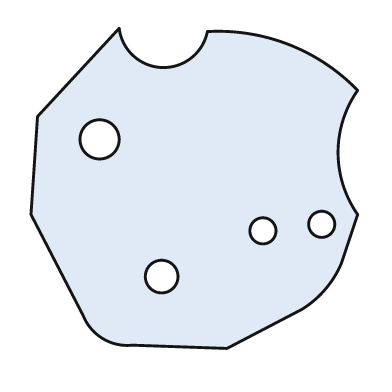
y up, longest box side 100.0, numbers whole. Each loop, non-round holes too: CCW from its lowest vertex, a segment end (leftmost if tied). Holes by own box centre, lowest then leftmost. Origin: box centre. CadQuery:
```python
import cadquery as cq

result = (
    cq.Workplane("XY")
    .moveTo(10.0, -49.0)
    .lineTo(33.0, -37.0)
    .threePointArc((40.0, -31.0), (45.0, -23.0))
    .lineTo(50.0, -8.0)
    .threePointArc((44.0, 11.0), (50.0, 30.0))
    .threePointArc((29.0, 44.0), (4.0, 48.0))
    .threePointArc((-10.0, 37.0), (-23.0, 49.0))
    .lineTo(-48.0, 22.0)
    .lineTo(-50.0, -8.0)
    .lineTo(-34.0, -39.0)
    .threePointArc((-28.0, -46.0), (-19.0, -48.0))
    .close()
    .moveTo(-10.0, -27.0)
    .circle(5.0)
    .moveTo(21.0, -13.0)
    .circle(4.0)
    .moveTo(39.0, -11.0)
    .circle(4.0)
    .moveTo(-29.0, 15.0)
    .circle(6.0)
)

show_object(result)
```